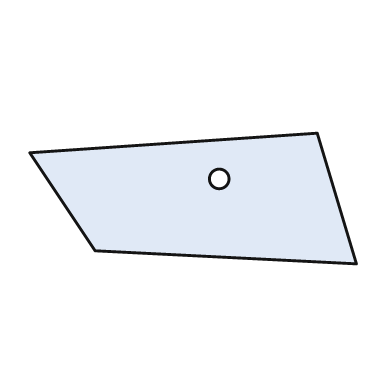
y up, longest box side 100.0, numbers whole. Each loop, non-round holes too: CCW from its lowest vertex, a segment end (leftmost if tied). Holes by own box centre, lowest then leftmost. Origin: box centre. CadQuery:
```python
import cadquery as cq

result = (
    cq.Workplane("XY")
    .moveTo(50.0, -20.0)
    .lineTo(38.0, 20.0)
    .lineTo(-50.0, 14.0)
    .lineTo(-30.0, -16.0)
    .close()
    .moveTo(8.0, 6.0)
    .circle(3.0)
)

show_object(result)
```